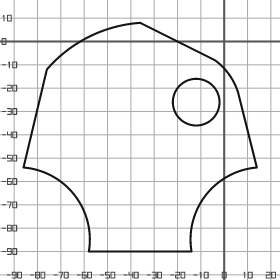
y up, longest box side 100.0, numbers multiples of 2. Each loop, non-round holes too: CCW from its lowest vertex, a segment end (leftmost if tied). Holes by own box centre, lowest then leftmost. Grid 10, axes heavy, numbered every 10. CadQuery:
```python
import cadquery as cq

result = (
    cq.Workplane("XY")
    .moveTo(-58.0, -90.0)
    .lineTo(-14.0, -90.0)
    .threePointArc((-8.0, -66.0), (14.0, -54.0))
    .lineTo(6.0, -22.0)
    .threePointArc((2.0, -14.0), (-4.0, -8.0))
    .lineTo(-36.0, 8.0)
    .threePointArc((-58.0, 2.0), (-76.0, -12.0))
    .lineTo(-86.0, -54.0)
    .threePointArc((-64.0, -66.0), (-58.0, -90.0))
    .close()
    .moveTo(-12.0, -26.0)
    .circle(10.0)
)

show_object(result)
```